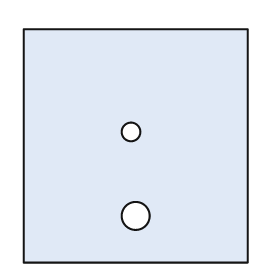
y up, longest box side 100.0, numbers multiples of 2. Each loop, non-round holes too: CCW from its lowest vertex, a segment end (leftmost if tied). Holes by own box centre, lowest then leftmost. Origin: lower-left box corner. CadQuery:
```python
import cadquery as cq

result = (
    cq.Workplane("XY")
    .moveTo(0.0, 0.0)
    .lineTo(96.0, 0.0)
    .lineTo(96.0, 100.0)
    .lineTo(0.0, 100.0)
    .close()
    .moveTo(48.0, 20.0)
    .circle(6.0)
    .moveTo(46.0, 56.0)
    .circle(4.0)
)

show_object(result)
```